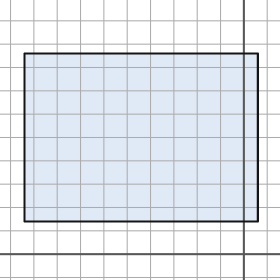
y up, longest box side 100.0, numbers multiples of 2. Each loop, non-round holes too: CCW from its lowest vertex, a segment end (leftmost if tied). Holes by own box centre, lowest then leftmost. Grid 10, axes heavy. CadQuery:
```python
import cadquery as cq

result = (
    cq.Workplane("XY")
    .moveTo(-94.0, 14.0)
    .lineTo(6.0, 14.0)
    .lineTo(6.0, 86.0)
    .lineTo(-94.0, 86.0)
    .close()
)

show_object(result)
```